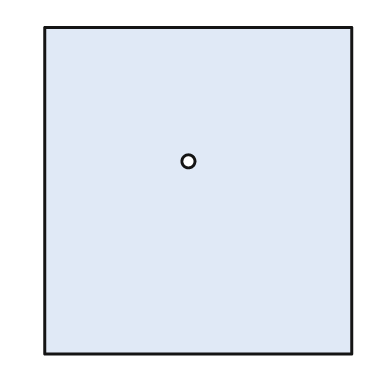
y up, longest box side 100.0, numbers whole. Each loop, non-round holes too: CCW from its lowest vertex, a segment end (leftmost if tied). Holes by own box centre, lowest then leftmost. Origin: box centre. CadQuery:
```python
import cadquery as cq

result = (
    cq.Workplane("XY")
    .moveTo(-47.0, -50.0)
    .lineTo(47.0, -50.0)
    .lineTo(47.0, 50.0)
    .lineTo(-47.0, 50.0)
    .close()
    .moveTo(-3.0, 9.0)
    .circle(2.0)
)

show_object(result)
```